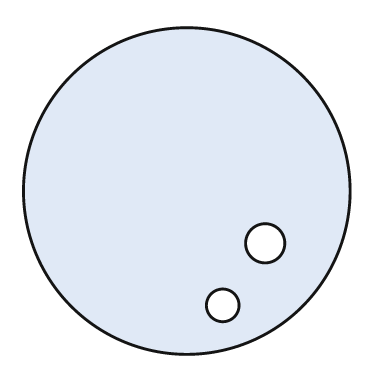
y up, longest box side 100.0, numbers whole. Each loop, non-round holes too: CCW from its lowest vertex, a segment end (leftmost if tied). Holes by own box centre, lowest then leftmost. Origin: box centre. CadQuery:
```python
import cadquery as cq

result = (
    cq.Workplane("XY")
    .moveTo(0.0, 0.0)
    .circle(50.0)
    .moveTo(11.0, -35.0)
    .circle(5.0)
    .moveTo(24.0, -16.0)
    .circle(6.0)
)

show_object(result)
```